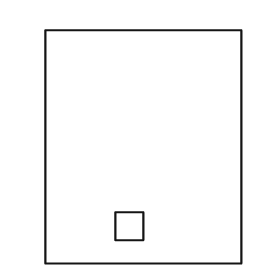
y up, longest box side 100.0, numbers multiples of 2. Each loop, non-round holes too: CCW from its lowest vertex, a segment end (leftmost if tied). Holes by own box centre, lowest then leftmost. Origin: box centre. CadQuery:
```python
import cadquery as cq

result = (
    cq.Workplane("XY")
    .moveTo(-42.0, -50.0)
    .lineTo(42.0, -50.0)
    .lineTo(42.0, 50.0)
    .lineTo(-42.0, 50.0)
    .close()
    .moveTo(-12.0, -40.0)
    .lineTo(0.0, -40.0)
    .lineTo(0.0, -28.0)
    .lineTo(-12.0, -28.0)
    .close()
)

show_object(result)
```